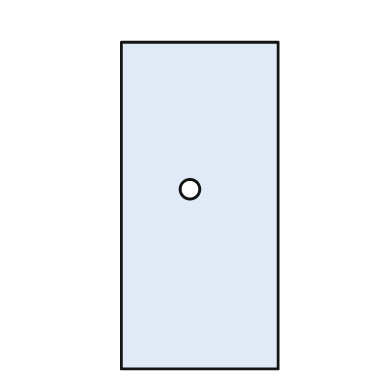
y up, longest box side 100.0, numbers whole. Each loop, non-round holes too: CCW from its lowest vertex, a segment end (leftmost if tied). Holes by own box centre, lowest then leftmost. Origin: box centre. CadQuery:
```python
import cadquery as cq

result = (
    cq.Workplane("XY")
    .moveTo(-24.0, -50.0)
    .lineTo(24.0, -50.0)
    .lineTo(24.0, 50.0)
    .lineTo(-24.0, 50.0)
    .close()
    .moveTo(-3.0, 5.0)
    .circle(3.0)
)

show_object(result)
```